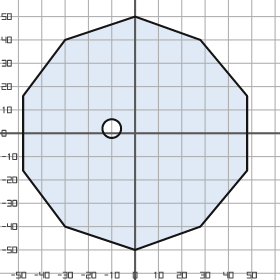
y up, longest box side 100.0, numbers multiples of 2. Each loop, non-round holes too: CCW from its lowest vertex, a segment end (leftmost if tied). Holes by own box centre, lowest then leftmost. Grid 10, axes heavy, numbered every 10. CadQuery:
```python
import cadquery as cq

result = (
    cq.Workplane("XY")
    .moveTo(0.0, -50.0)
    .lineTo(28.0, -40.0)
    .lineTo(48.0, -16.0)
    .lineTo(48.0, 16.0)
    .lineTo(28.0, 40.0)
    .lineTo(0.0, 50.0)
    .lineTo(-30.0, 40.0)
    .lineTo(-48.0, 16.0)
    .lineTo(-48.0, -16.0)
    .lineTo(-30.0, -40.0)
    .close()
    .moveTo(-10.0, 2.0)
    .circle(4.0)
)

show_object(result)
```